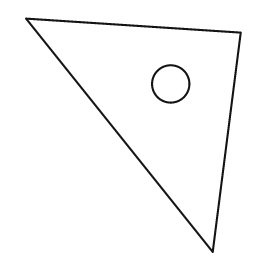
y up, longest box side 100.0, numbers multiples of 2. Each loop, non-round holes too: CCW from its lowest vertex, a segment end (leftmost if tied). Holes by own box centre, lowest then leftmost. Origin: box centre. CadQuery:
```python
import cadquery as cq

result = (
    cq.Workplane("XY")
    .moveTo(34.0, -50.0)
    .lineTo(46.0, 44.0)
    .lineTo(-46.0, 50.0)
    .close()
    .moveTo(16.0, 22.0)
    .circle(8.0)
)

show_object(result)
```